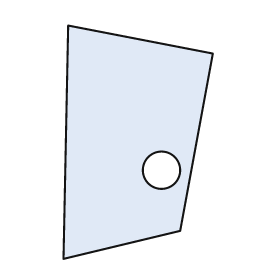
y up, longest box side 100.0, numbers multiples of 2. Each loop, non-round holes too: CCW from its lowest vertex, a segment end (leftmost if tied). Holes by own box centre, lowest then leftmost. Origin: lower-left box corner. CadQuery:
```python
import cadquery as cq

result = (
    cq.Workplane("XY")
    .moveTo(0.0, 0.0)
    .lineTo(50.0, 12.0)
    .lineTo(64.0, 88.0)
    .lineTo(2.0, 100.0)
    .close()
    .moveTo(42.0, 38.0)
    .circle(8.0)
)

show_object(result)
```